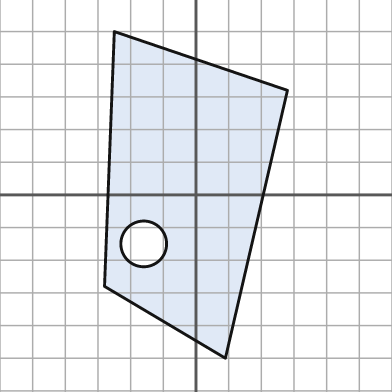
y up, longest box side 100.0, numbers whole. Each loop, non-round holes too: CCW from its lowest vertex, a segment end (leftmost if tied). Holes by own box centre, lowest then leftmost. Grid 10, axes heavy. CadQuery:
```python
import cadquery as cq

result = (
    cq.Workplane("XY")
    .moveTo(9.0, -50.0)
    .lineTo(28.0, 32.0)
    .lineTo(-25.0, 50.0)
    .lineTo(-28.0, -28.0)
    .close()
    .moveTo(-16.0, -15.0)
    .circle(7.0)
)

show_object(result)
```